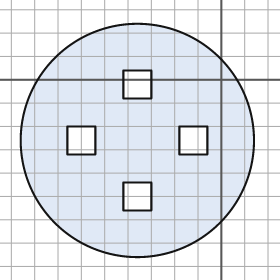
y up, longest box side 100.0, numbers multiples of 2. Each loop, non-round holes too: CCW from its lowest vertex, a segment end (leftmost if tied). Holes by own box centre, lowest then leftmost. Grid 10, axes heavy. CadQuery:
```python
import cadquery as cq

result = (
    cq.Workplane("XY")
    .moveTo(-36.0, -26.0)
    .circle(50.0)
    .moveTo(-42.0, -56.0)
    .lineTo(-30.0, -56.0)
    .lineTo(-30.0, -44.0)
    .lineTo(-42.0, -44.0)
    .close()
    .moveTo(-66.0, -32.0)
    .lineTo(-54.0, -32.0)
    .lineTo(-54.0, -20.0)
    .lineTo(-66.0, -20.0)
    .close()
    .moveTo(-18.0, -32.0)
    .lineTo(-6.0, -32.0)
    .lineTo(-6.0, -20.0)
    .lineTo(-18.0, -20.0)
    .close()
    .moveTo(-42.0, -8.0)
    .lineTo(-30.0, -8.0)
    .lineTo(-30.0, 4.0)
    .lineTo(-42.0, 4.0)
    .close()
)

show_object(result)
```